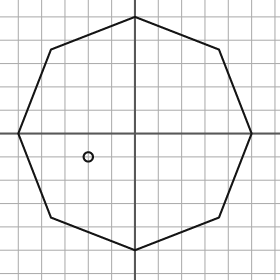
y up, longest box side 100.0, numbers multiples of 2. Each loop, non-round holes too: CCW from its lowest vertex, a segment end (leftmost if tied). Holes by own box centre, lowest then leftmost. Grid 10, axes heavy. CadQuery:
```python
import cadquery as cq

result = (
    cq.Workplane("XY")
    .moveTo(0.0, -50.0)
    .lineTo(36.0, -36.0)
    .lineTo(50.0, 0.0)
    .lineTo(36.0, 36.0)
    .lineTo(0.0, 50.0)
    .lineTo(-36.0, 36.0)
    .lineTo(-50.0, 0.0)
    .lineTo(-36.0, -36.0)
    .close()
    .moveTo(-20.0, -10.0)
    .circle(2.0)
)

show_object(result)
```